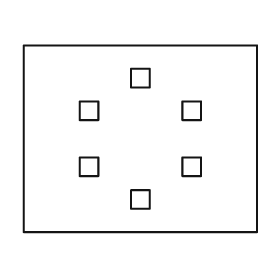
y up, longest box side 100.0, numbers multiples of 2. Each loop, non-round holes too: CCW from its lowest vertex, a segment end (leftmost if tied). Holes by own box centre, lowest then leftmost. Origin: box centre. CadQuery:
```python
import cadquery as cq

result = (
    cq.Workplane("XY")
    .moveTo(-50.0, -40.0)
    .lineTo(50.0, -40.0)
    .lineTo(50.0, 40.0)
    .lineTo(-50.0, 40.0)
    .close()
    .moveTo(-4.0, -30.0)
    .lineTo(4.0, -30.0)
    .lineTo(4.0, -22.0)
    .lineTo(-4.0, -22.0)
    .close()
    .moveTo(-26.0, -16.0)
    .lineTo(-18.0, -16.0)
    .lineTo(-18.0, -8.0)
    .lineTo(-26.0, -8.0)
    .close()
    .moveTo(18.0, -16.0)
    .lineTo(26.0, -16.0)
    .lineTo(26.0, -8.0)
    .lineTo(18.0, -8.0)
    .close()
    .moveTo(-26.0, 8.0)
    .lineTo(-18.0, 8.0)
    .lineTo(-18.0, 16.0)
    .lineTo(-26.0, 16.0)
    .close()
    .moveTo(18.0, 8.0)
    .lineTo(26.0, 8.0)
    .lineTo(26.0, 16.0)
    .lineTo(18.0, 16.0)
    .close()
    .moveTo(-4.0, 22.0)
    .lineTo(4.0, 22.0)
    .lineTo(4.0, 30.0)
    .lineTo(-4.0, 30.0)
    .close()
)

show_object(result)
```